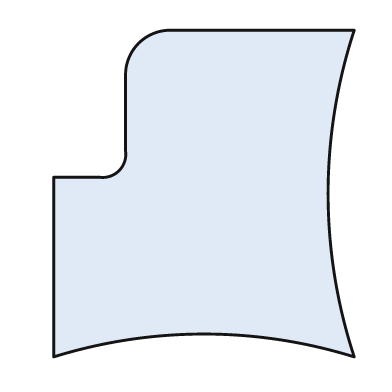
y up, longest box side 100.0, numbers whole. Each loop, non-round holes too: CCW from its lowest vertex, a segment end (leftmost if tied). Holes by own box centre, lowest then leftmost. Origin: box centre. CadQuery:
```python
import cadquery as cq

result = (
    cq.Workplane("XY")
    .moveTo(-46.0, -50.0)
    .threePointArc((0.0, -43.0), (46.0, -50.0))
    .threePointArc((38.0, 0.0), (46.0, 50.0))
    .lineTo(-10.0, 50.0)
    .threePointArc((-20.0, 46.0), (-24.0, 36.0))
    .lineTo(-24.0, 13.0)
    .threePointArc((-26.0, 7.0), (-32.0, 5.0))
    .lineTo(-46.0, 5.0)
    .close()
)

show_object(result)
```